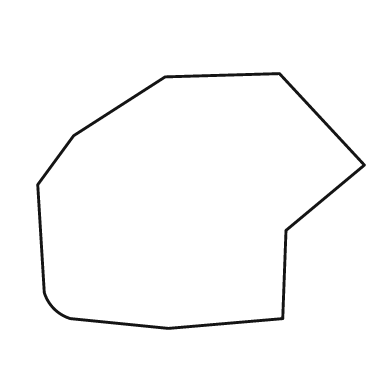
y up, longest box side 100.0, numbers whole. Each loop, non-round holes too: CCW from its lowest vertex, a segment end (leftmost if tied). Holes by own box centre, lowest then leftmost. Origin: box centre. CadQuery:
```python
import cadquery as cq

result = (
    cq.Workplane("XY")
    .moveTo(-10.0, -39.0)
    .lineTo(25.0, -36.0)
    .lineTo(26.0, -9.0)
    .lineTo(50.0, 11.0)
    .lineTo(24.0, 39.0)
    .lineTo(-11.0, 38.0)
    .lineTo(-39.0, 20.0)
    .lineTo(-50.0, 5.0)
    .lineTo(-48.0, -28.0)
    .threePointArc((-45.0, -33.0), (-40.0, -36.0))
    .close()
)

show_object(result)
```